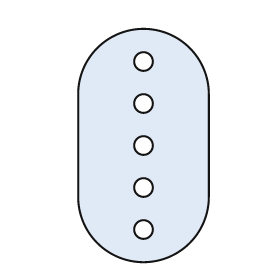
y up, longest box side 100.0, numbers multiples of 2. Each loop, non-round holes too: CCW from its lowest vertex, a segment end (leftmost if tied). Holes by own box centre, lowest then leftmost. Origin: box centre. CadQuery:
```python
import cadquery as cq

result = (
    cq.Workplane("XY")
    .moveTo(-28.0, -22.0)
    .threePointArc((0.0, -50.0), (28.0, -22.0))
    .lineTo(28.0, 22.0)
    .threePointArc((0.0, 50.0), (-28.0, 22.0))
    .close()
    .moveTo(0.0, -36.0)
    .circle(4.0)
    .moveTo(0.0, -18.0)
    .circle(4.0)
    .moveTo(0.0, 0.0)
    .circle(4.0)
    .moveTo(0.0, 18.0)
    .circle(4.0)
    .moveTo(0.0, 36.0)
    .circle(4.0)
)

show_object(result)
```